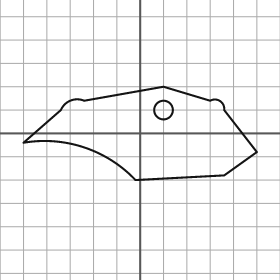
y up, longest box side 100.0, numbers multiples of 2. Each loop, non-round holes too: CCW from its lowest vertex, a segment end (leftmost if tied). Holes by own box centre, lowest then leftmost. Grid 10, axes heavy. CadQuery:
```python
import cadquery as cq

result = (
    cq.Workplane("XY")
    .moveTo(-2.0, -20.0)
    .lineTo(36.0, -18.0)
    .lineTo(50.0, -8.0)
    .lineTo(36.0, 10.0)
    .threePointArc((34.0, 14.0), (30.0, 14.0))
    .lineTo(10.0, 20.0)
    .lineTo(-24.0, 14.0)
    .threePointArc((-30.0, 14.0), (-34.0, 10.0))
    .lineTo(-50.0, -4.0)
    .threePointArc((-24.0, -6.0), (-2.0, -20.0))
    .close()
    .moveTo(10.0, 10.0)
    .circle(4.0)
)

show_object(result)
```